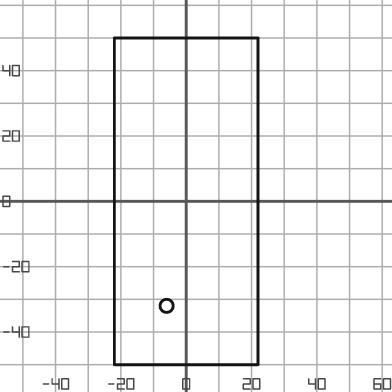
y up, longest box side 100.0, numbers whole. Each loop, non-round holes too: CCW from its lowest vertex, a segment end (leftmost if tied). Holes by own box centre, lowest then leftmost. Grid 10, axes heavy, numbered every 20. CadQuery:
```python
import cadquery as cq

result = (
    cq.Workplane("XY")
    .moveTo(-22.0, -50.0)
    .lineTo(22.0, -50.0)
    .lineTo(22.0, 50.0)
    .lineTo(-22.0, 50.0)
    .close()
    .moveTo(-6.0, -32.0)
    .circle(2.0)
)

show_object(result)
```